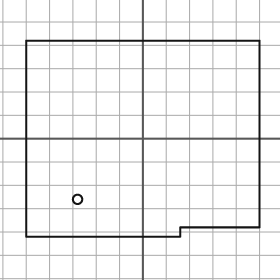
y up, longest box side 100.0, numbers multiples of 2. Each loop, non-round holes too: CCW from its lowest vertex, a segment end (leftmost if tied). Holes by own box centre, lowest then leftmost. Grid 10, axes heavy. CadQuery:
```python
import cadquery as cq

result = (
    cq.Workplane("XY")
    .moveTo(-50.0, -42.0)
    .lineTo(16.0, -42.0)
    .lineTo(16.0, -38.0)
    .lineTo(50.0, -38.0)
    .lineTo(50.0, 42.0)
    .lineTo(-50.0, 42.0)
    .close()
    .moveTo(-28.0, -26.0)
    .circle(2.0)
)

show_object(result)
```